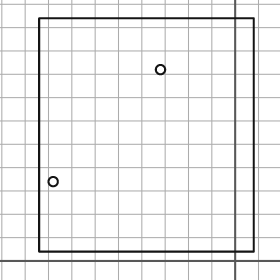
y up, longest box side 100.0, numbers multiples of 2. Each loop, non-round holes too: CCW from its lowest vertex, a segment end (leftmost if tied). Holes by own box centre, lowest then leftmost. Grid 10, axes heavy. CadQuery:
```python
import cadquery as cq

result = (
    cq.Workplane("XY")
    .moveTo(-84.0, 4.0)
    .lineTo(8.0, 4.0)
    .lineTo(8.0, 104.0)
    .lineTo(-84.0, 104.0)
    .close()
    .moveTo(-78.0, 34.0)
    .circle(2.0)
    .moveTo(-32.0, 82.0)
    .circle(2.0)
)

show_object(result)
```